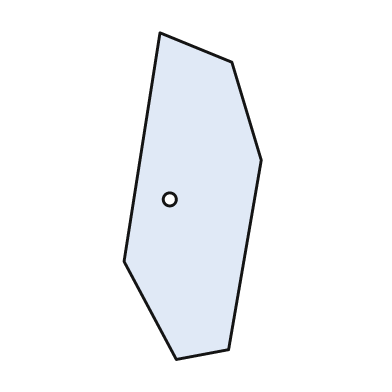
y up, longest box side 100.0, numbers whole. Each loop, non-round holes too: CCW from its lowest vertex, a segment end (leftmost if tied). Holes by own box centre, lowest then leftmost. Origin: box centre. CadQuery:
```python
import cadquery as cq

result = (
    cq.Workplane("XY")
    .moveTo(-5.0, -50.0)
    .lineTo(11.0, -47.0)
    .lineTo(21.0, 11.0)
    .lineTo(12.0, 41.0)
    .lineTo(-10.0, 50.0)
    .lineTo(-21.0, -20.0)
    .close()
    .moveTo(-7.0, -1.0)
    .circle(2.0)
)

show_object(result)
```